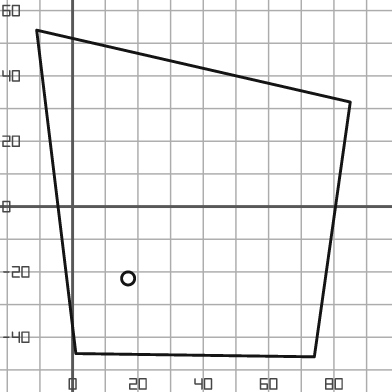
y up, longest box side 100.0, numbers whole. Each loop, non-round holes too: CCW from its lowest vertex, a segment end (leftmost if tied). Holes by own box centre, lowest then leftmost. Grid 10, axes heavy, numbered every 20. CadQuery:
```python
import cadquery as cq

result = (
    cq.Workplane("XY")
    .moveTo(74.0, -46.0)
    .lineTo(85.0, 32.0)
    .lineTo(-11.0, 54.0)
    .lineTo(1.0, -45.0)
    .close()
    .moveTo(17.0, -22.0)
    .circle(2.0)
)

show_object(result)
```